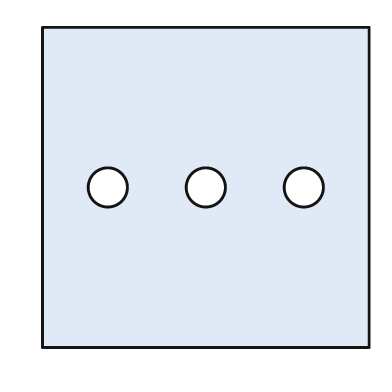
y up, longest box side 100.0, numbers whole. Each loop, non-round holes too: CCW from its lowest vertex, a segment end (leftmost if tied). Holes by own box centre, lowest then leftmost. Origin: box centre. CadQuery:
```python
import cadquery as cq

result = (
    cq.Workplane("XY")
    .moveTo(-50.0, -49.0)
    .lineTo(50.0, -49.0)
    .lineTo(50.0, 49.0)
    .lineTo(-50.0, 49.0)
    .close()
    .moveTo(-30.0, 0.0)
    .circle(6.0)
    .moveTo(0.0, 0.0)
    .circle(6.0)
    .moveTo(30.0, 0.0)
    .circle(6.0)
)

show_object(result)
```